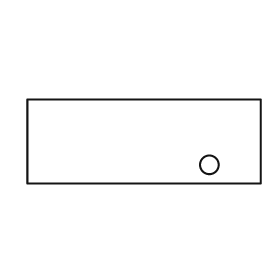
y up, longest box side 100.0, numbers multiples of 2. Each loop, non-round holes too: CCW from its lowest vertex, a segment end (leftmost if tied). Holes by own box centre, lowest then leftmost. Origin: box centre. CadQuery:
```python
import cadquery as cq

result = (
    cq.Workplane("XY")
    .moveTo(-50.0, -18.0)
    .lineTo(50.0, -18.0)
    .lineTo(50.0, 18.0)
    .lineTo(-50.0, 18.0)
    .close()
    .moveTo(28.0, -10.0)
    .circle(4.0)
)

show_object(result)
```